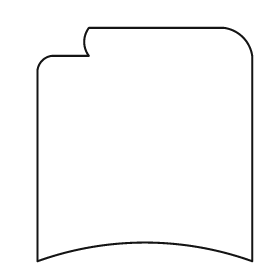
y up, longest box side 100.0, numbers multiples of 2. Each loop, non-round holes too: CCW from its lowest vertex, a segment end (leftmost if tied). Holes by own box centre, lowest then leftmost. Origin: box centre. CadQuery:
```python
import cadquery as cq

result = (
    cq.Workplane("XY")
    .moveTo(-46.0, -50.0)
    .threePointArc((0.0, -42.0), (46.0, -50.0))
    .lineTo(46.0, 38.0)
    .threePointArc((42.0, 46.0), (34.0, 50.0))
    .lineTo(-24.0, 50.0)
    .threePointArc((-26.0, 44.0), (-24.0, 38.0))
    .lineTo(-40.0, 38.0)
    .threePointArc((-44.0, 36.0), (-46.0, 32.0))
    .close()
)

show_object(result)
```